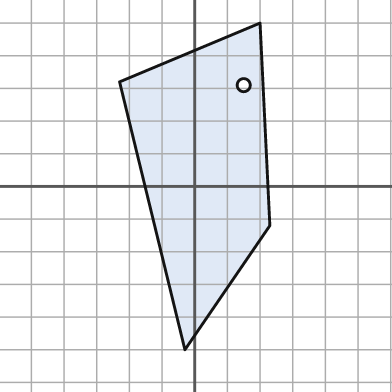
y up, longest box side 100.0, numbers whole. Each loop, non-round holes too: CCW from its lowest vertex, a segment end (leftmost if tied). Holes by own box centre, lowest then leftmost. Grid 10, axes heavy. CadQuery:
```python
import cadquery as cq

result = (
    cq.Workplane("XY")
    .moveTo(-3.0, -50.0)
    .lineTo(23.0, -12.0)
    .lineTo(20.0, 50.0)
    .lineTo(-23.0, 32.0)
    .close()
    .moveTo(15.0, 31.0)
    .circle(2.0)
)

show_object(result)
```